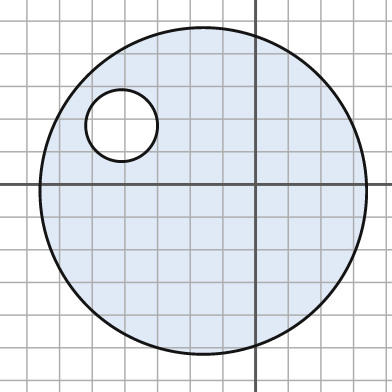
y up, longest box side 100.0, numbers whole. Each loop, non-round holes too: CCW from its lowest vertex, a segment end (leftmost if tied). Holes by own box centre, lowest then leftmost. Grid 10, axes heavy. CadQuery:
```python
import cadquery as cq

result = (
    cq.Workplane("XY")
    .moveTo(-16.0, -2.0)
    .circle(50.0)
    .moveTo(-41.0, 18.0)
    .circle(11.0)
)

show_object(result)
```